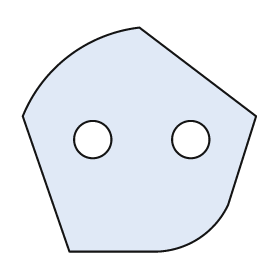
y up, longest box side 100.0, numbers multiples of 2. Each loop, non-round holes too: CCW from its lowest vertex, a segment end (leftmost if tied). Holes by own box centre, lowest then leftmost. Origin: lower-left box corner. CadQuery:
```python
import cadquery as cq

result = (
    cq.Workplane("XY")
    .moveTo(20.0, 0.0)
    .lineTo(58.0, 0.0)
    .threePointArc((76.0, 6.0), (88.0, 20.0))
    .lineTo(100.0, 58.0)
    .lineTo(50.0, 96.0)
    .threePointArc((20.0, 84.0), (0.0, 58.0))
    .close()
    .moveTo(30.0, 48.0)
    .circle(8.0)
    .moveTo(72.0, 48.0)
    .circle(8.0)
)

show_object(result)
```